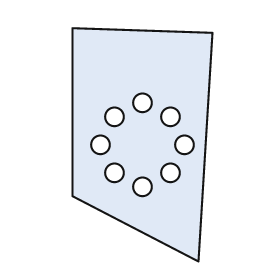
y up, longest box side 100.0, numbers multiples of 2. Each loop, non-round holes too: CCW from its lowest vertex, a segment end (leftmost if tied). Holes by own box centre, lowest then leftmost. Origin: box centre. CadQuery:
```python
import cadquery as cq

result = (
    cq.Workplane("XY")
    .moveTo(24.0, -50.0)
    .lineTo(30.0, 48.0)
    .lineTo(-30.0, 50.0)
    .lineTo(-30.0, -22.0)
    .close()
    .moveTo(0.0, -18.0)
    .circle(4.0)
    .moveTo(-12.0, -12.0)
    .circle(4.0)
    .moveTo(12.0, -12.0)
    .circle(4.0)
    .moveTo(-18.0, 0.0)
    .circle(4.0)
    .moveTo(18.0, 0.0)
    .circle(4.0)
    .moveTo(-12.0, 12.0)
    .circle(4.0)
    .moveTo(12.0, 12.0)
    .circle(4.0)
    .moveTo(0.0, 18.0)
    .circle(4.0)
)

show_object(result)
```